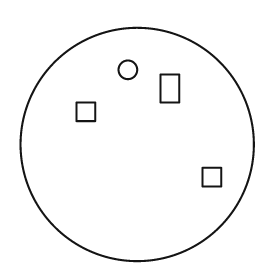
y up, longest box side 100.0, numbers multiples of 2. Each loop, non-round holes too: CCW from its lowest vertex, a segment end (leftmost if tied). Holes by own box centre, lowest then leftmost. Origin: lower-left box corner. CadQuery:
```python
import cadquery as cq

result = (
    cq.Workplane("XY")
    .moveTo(50.0, 50.0)
    .circle(50.0)
    .moveTo(78.0, 32.0)
    .lineTo(86.0, 32.0)
    .lineTo(86.0, 40.0)
    .lineTo(78.0, 40.0)
    .close()
    .moveTo(24.0, 60.0)
    .lineTo(32.0, 60.0)
    .lineTo(32.0, 68.0)
    .lineTo(24.0, 68.0)
    .close()
    .moveTo(60.0, 68.0)
    .lineTo(68.0, 68.0)
    .lineTo(68.0, 80.0)
    .lineTo(60.0, 80.0)
    .close()
    .moveTo(46.0, 82.0)
    .circle(4.0)
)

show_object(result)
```